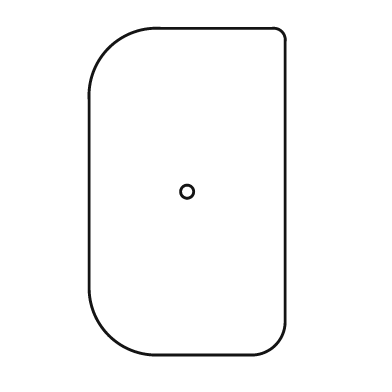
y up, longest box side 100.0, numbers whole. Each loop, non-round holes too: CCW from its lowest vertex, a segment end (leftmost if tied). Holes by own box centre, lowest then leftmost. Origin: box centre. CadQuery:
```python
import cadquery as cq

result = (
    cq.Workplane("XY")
    .moveTo(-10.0, -50.0)
    .lineTo(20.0, -50.0)
    .threePointArc((27.0, -47.0), (30.0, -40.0))
    .lineTo(30.0, 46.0)
    .threePointArc((29.0, 49.0), (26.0, 50.0))
    .lineTo(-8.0, 50.0)
    .threePointArc((-24.0, 44.0), (-30.0, 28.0))
    .lineTo(-30.0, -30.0)
    .threePointArc((-24.0, -44.0), (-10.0, -50.0))
    .close()
    .moveTo(0.0, 0.0)
    .circle(2.0)
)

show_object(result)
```